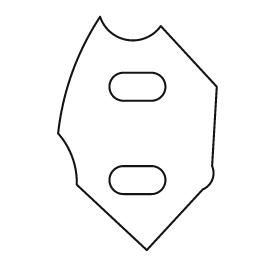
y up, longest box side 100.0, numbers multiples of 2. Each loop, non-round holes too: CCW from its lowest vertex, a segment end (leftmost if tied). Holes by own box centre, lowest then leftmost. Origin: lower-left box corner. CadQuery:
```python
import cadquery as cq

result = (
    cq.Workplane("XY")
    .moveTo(38.0, 0.0)
    .lineTo(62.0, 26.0)
    .threePointArc((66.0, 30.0), (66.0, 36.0))
    .lineTo(68.0, 70.0)
    .lineTo(44.0, 96.0)
    .threePointArc((30.0, 90.0), (18.0, 100.0))
    .threePointArc((6.0, 76.0), (0.0, 50.0))
    .threePointArc((6.0, 40.0), (8.0, 28.0))
    .close()
    .moveTo(28.0, 24.0)
    .lineTo(40.0, 24.0)
    .threePointArc((46.0, 30.0), (40.0, 36.0))
    .lineTo(28.0, 36.0)
    .threePointArc((22.0, 30.0), (28.0, 24.0))
    .close()
    .moveTo(28.0, 64.0)
    .lineTo(40.0, 64.0)
    .threePointArc((46.0, 70.0), (40.0, 76.0))
    .lineTo(28.0, 76.0)
    .threePointArc((22.0, 70.0), (28.0, 64.0))
    .close()
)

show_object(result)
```